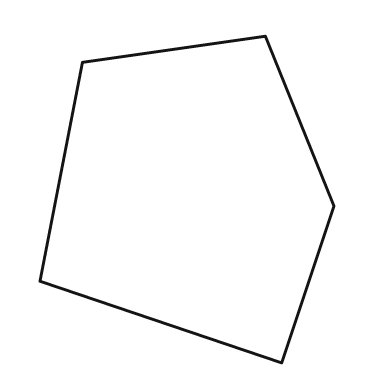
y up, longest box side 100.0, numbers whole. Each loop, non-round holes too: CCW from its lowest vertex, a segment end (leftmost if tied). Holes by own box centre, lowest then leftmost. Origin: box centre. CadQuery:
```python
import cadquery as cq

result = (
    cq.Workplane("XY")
    .moveTo(29.0, -50.0)
    .lineTo(45.0, -2.0)
    .lineTo(24.0, 50.0)
    .lineTo(-32.0, 42.0)
    .lineTo(-45.0, -25.0)
    .close()
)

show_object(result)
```